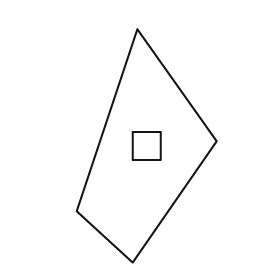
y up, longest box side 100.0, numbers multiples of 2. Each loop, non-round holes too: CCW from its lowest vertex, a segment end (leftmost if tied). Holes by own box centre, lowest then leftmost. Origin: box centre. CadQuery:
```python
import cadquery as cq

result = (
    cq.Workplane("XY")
    .moveTo(-6.0, -50.0)
    .lineTo(30.0, 2.0)
    .lineTo(-4.0, 50.0)
    .lineTo(-30.0, -28.0)
    .close()
    .moveTo(-6.0, -6.0)
    .lineTo(6.0, -6.0)
    .lineTo(6.0, 6.0)
    .lineTo(-6.0, 6.0)
    .close()
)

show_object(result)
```